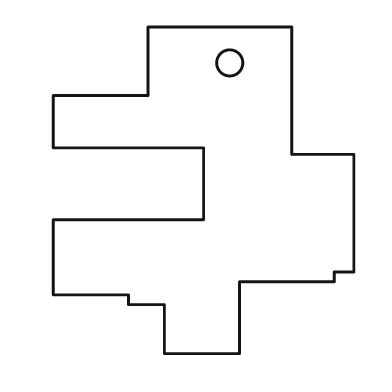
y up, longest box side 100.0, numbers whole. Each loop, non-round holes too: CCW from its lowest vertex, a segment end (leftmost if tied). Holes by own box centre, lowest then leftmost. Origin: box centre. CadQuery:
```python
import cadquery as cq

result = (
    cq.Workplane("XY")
    .moveTo(-12.0, -50.0)
    .lineTo(11.0, -50.0)
    .lineTo(11.0, -28.0)
    .lineTo(40.0, -28.0)
    .lineTo(40.0, -25.0)
    .lineTo(46.0, -25.0)
    .lineTo(46.0, 11.0)
    .lineTo(27.0, 11.0)
    .lineTo(27.0, 50.0)
    .lineTo(-17.0, 50.0)
    .lineTo(-17.0, 29.0)
    .lineTo(-46.0, 29.0)
    .lineTo(-46.0, 13.0)
    .lineTo(0.0, 13.0)
    .lineTo(0.0, -9.0)
    .lineTo(-46.0, -9.0)
    .lineTo(-46.0, -32.0)
    .lineTo(-23.0, -32.0)
    .lineTo(-23.0, -35.0)
    .lineTo(-12.0, -35.0)
    .close()
    .moveTo(8.0, 39.0)
    .circle(4.0)
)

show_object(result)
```